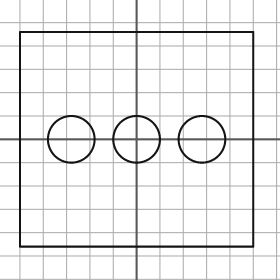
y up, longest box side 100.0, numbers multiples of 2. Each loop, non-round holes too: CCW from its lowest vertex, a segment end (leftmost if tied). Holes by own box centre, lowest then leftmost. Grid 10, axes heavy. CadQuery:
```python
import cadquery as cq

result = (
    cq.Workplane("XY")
    .moveTo(-50.0, -46.0)
    .lineTo(50.0, -46.0)
    .lineTo(50.0, 46.0)
    .lineTo(-50.0, 46.0)
    .close()
    .moveTo(-28.0, 0.0)
    .circle(10.0)
    .moveTo(0.0, 0.0)
    .circle(10.0)
    .moveTo(28.0, 0.0)
    .circle(10.0)
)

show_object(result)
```